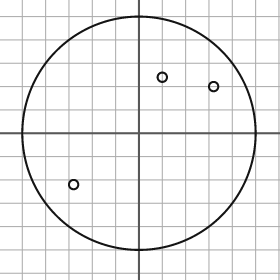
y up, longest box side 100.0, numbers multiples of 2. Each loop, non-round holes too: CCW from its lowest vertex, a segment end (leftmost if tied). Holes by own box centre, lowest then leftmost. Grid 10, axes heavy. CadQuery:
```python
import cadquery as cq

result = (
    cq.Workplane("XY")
    .moveTo(0.0, 0.0)
    .circle(50.0)
    .moveTo(-28.0, -22.0)
    .circle(2.0)
    .moveTo(32.0, 20.0)
    .circle(2.0)
    .moveTo(10.0, 24.0)
    .circle(2.0)
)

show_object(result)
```